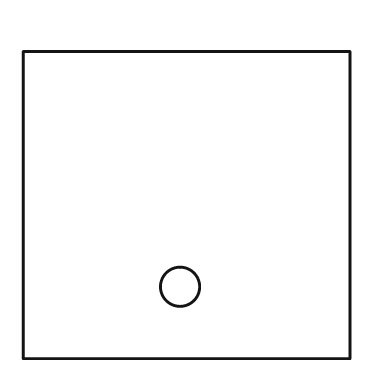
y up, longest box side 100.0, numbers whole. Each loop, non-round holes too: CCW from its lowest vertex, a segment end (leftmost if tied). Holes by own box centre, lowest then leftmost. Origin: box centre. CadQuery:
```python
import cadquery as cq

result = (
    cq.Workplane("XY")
    .moveTo(-50.0, -47.0)
    .lineTo(50.0, -47.0)
    .lineTo(50.0, 47.0)
    .lineTo(-50.0, 47.0)
    .close()
    .moveTo(-2.0, -25.0)
    .circle(6.0)
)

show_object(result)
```